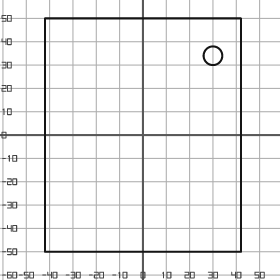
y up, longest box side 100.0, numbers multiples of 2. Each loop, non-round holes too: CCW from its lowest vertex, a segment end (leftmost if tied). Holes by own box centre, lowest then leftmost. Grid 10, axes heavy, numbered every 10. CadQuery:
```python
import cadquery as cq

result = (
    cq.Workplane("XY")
    .moveTo(-42.0, -50.0)
    .lineTo(42.0, -50.0)
    .lineTo(42.0, 50.0)
    .lineTo(-42.0, 50.0)
    .close()
    .moveTo(30.0, 34.0)
    .circle(4.0)
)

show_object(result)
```